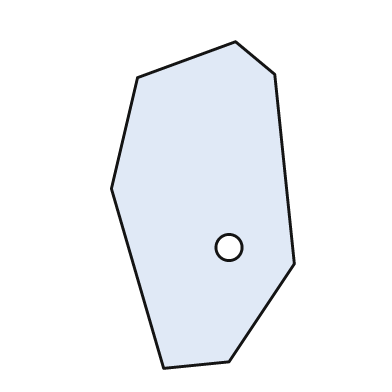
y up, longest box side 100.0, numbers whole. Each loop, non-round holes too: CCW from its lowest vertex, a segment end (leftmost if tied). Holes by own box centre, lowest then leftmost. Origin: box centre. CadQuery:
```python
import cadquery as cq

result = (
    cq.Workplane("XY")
    .moveTo(-12.0, -50.0)
    .lineTo(8.0, -48.0)
    .lineTo(28.0, -18.0)
    .lineTo(22.0, 40.0)
    .lineTo(10.0, 50.0)
    .lineTo(-20.0, 39.0)
    .lineTo(-28.0, 5.0)
    .close()
    .moveTo(8.0, -13.0)
    .circle(4.0)
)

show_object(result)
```